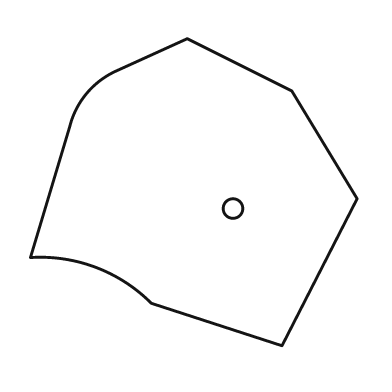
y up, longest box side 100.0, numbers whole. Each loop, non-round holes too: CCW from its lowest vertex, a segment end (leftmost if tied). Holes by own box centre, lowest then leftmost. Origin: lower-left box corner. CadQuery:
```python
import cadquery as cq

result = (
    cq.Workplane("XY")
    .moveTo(77.0, 0.0)
    .lineTo(100.0, 45.0)
    .lineTo(80.0, 78.0)
    .lineTo(48.0, 94.0)
    .lineTo(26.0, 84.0)
    .threePointArc((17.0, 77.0), (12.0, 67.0))
    .lineTo(0.0, 27.0)
    .threePointArc((20.0, 24.0), (37.0, 13.0))
    .close()
    .moveTo(62.0, 42.0)
    .circle(3.0)
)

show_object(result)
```